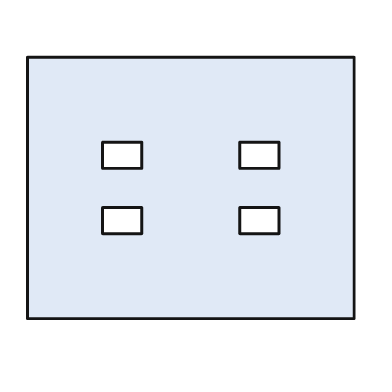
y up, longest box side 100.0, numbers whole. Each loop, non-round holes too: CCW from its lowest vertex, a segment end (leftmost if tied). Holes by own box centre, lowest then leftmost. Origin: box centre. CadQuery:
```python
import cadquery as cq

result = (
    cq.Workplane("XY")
    .moveTo(-50.0, -40.0)
    .lineTo(50.0, -40.0)
    .lineTo(50.0, 40.0)
    .lineTo(-50.0, 40.0)
    .close()
    .moveTo(-27.0, -14.0)
    .lineTo(-15.0, -14.0)
    .lineTo(-15.0, -6.0)
    .lineTo(-27.0, -6.0)
    .close()
    .moveTo(15.0, -14.0)
    .lineTo(27.0, -14.0)
    .lineTo(27.0, -6.0)
    .lineTo(15.0, -6.0)
    .close()
    .moveTo(-27.0, 6.0)
    .lineTo(-15.0, 6.0)
    .lineTo(-15.0, 14.0)
    .lineTo(-27.0, 14.0)
    .close()
    .moveTo(15.0, 6.0)
    .lineTo(27.0, 6.0)
    .lineTo(27.0, 14.0)
    .lineTo(15.0, 14.0)
    .close()
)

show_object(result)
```